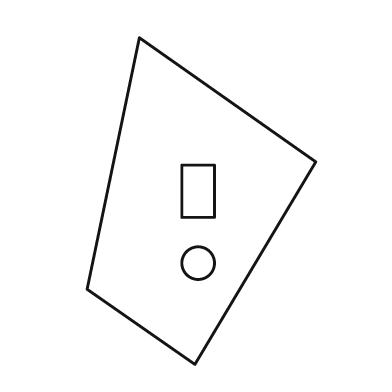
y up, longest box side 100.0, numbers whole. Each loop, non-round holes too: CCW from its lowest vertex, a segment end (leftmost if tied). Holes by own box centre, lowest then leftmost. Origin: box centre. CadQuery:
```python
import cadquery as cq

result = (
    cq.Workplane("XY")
    .moveTo(-2.0, -50.0)
    .lineTo(35.0, 12.0)
    .lineTo(-19.0, 50.0)
    .lineTo(-35.0, -27.0)
    .close()
    .moveTo(-1.0, -19.0)
    .circle(5.0)
    .moveTo(-6.0, -5.0)
    .lineTo(4.0, -5.0)
    .lineTo(4.0, 11.0)
    .lineTo(-6.0, 11.0)
    .close()
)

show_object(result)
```